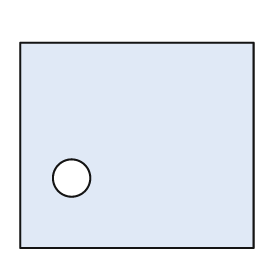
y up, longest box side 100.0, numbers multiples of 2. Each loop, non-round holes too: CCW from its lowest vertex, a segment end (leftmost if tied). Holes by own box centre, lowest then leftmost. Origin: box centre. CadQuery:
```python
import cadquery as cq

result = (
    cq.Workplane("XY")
    .moveTo(-50.0, -44.0)
    .lineTo(50.0, -44.0)
    .lineTo(50.0, 44.0)
    .lineTo(-50.0, 44.0)
    .close()
    .moveTo(-28.0, -14.0)
    .circle(8.0)
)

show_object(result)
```